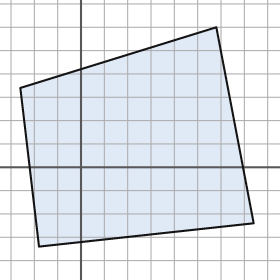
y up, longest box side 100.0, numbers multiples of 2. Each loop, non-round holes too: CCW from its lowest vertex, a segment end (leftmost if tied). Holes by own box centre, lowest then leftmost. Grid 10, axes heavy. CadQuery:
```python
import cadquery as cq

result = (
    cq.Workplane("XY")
    .moveTo(-18.0, -34.0)
    .lineTo(74.0, -24.0)
    .lineTo(58.0, 60.0)
    .lineTo(-26.0, 34.0)
    .close()
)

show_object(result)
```